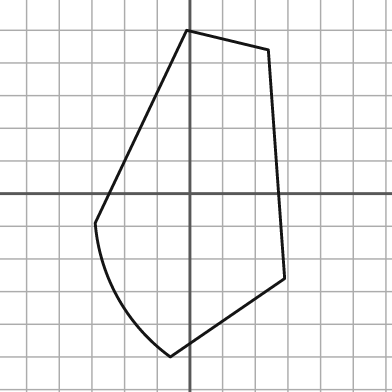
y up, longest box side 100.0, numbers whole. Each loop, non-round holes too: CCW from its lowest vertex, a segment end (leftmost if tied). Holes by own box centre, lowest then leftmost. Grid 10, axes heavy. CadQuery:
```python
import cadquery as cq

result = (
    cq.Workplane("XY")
    .moveTo(-6.0, -50.0)
    .lineTo(29.0, -26.0)
    .lineTo(24.0, 44.0)
    .lineTo(-1.0, 50.0)
    .lineTo(-29.0, -9.0)
    .threePointArc((-22.0, -32.0), (-6.0, -50.0))
    .close()
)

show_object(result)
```